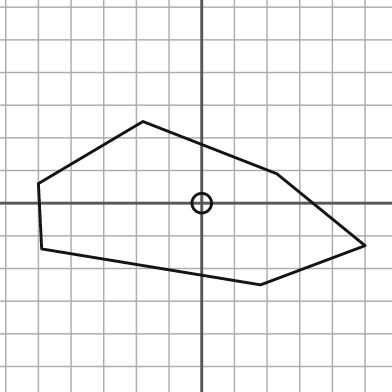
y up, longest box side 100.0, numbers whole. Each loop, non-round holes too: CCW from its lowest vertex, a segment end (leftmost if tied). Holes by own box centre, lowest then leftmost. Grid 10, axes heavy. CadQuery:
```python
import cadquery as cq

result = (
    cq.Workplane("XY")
    .moveTo(18.0, -25.0)
    .lineTo(50.0, -13.0)
    .lineTo(23.0, 9.0)
    .lineTo(-18.0, 25.0)
    .lineTo(-50.0, 6.0)
    .lineTo(-49.0, -14.0)
    .close()
    .moveTo(0.0, 0.0)
    .circle(3.0)
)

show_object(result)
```